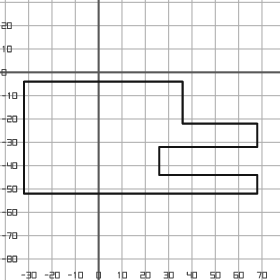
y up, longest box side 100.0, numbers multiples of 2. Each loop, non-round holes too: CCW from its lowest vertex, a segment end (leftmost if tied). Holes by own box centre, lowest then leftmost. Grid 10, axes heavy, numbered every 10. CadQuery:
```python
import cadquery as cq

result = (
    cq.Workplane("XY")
    .moveTo(-32.0, -52.0)
    .lineTo(68.0, -52.0)
    .lineTo(68.0, -44.0)
    .lineTo(26.0, -44.0)
    .lineTo(26.0, -32.0)
    .lineTo(68.0, -32.0)
    .lineTo(68.0, -22.0)
    .lineTo(36.0, -22.0)
    .lineTo(36.0, -4.0)
    .lineTo(-32.0, -4.0)
    .close()
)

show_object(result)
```